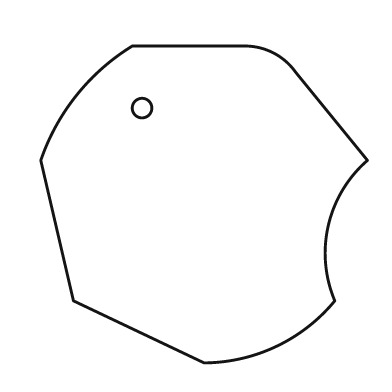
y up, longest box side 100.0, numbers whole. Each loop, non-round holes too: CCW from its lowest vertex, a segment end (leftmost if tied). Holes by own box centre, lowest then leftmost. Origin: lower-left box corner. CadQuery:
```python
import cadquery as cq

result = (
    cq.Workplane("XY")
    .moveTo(50.0, 0.0)
    .threePointArc((72.0, 5.0), (90.0, 19.0))
    .threePointArc((88.0, 42.0), (100.0, 62.0))
    .lineTo(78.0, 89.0)
    .threePointArc((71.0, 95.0), (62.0, 97.0))
    .lineTo(28.0, 97.0)
    .threePointArc((11.0, 82.0), (0.0, 62.0))
    .lineTo(10.0, 19.0)
    .close()
    .moveTo(31.0, 78.0)
    .circle(3.0)
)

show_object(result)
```